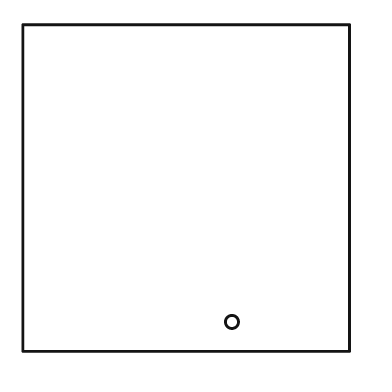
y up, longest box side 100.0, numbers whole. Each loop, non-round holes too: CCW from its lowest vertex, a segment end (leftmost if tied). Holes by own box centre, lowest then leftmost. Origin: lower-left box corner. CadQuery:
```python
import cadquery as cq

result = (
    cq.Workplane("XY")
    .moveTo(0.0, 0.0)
    .lineTo(100.0, 0.0)
    .lineTo(100.0, 100.0)
    .lineTo(0.0, 100.0)
    .close()
    .moveTo(64.0, 9.0)
    .circle(2.0)
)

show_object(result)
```